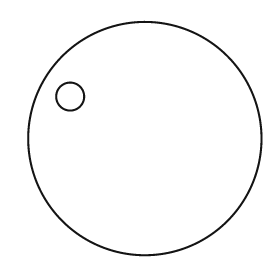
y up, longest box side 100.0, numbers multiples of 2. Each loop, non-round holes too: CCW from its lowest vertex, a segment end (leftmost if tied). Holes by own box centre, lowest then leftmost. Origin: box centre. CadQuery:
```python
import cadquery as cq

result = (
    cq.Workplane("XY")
    .moveTo(0.0, 0.0)
    .circle(50.0)
    .moveTo(-32.0, 18.0)
    .circle(6.0)
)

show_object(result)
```